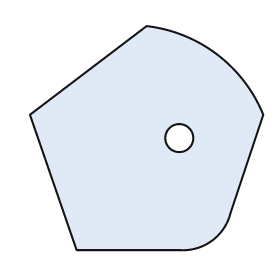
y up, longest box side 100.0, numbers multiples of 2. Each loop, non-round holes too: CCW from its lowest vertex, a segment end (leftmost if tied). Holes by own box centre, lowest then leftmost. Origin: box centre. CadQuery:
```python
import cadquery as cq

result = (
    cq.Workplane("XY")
    .moveTo(-30.0, -48.0)
    .lineTo(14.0, -48.0)
    .threePointArc((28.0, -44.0), (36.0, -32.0))
    .lineTo(50.0, 10.0)
    .threePointArc((30.0, 36.0), (0.0, 48.0))
    .lineTo(-50.0, 10.0)
    .close()
    .moveTo(14.0, 0.0)
    .circle(6.0)
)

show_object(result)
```